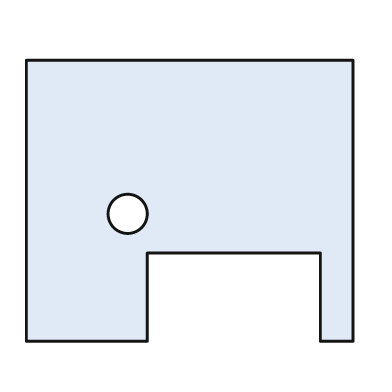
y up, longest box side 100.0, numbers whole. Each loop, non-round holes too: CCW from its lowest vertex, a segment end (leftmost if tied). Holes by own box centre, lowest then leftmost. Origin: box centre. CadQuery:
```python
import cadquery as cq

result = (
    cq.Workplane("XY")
    .moveTo(-50.0, -43.0)
    .lineTo(-13.0, -43.0)
    .lineTo(-13.0, -16.0)
    .lineTo(40.0, -16.0)
    .lineTo(40.0, -43.0)
    .lineTo(50.0, -43.0)
    .lineTo(50.0, 43.0)
    .lineTo(-50.0, 43.0)
    .close()
    .moveTo(-19.0, -4.0)
    .circle(6.0)
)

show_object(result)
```